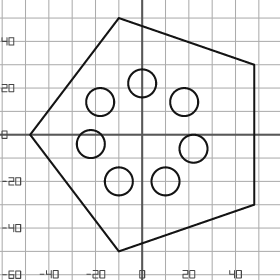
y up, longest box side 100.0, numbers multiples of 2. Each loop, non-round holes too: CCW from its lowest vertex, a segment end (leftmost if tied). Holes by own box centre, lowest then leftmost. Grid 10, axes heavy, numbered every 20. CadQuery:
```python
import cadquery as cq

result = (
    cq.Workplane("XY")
    .moveTo(-10.0, -50.0)
    .lineTo(48.0, -30.0)
    .lineTo(48.0, 30.0)
    .lineTo(-10.0, 50.0)
    .lineTo(-48.0, 0.0)
    .close()
    .moveTo(-10.0, -20.0)
    .circle(6.0)
    .moveTo(10.0, -20.0)
    .circle(6.0)
    .moveTo(22.0, -6.0)
    .circle(6.0)
    .moveTo(-22.0, -4.0)
    .circle(6.0)
    .moveTo(-18.0, 14.0)
    .circle(6.0)
    .moveTo(18.0, 14.0)
    .circle(6.0)
    .moveTo(0.0, 22.0)
    .circle(6.0)
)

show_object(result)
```